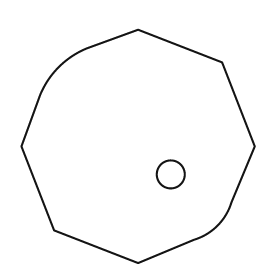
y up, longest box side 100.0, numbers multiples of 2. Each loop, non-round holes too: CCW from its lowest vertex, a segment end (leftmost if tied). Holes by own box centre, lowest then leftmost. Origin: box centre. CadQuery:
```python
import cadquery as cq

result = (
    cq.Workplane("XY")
    .moveTo(0.0, -50.0)
    .lineTo(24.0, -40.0)
    .threePointArc((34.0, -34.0), (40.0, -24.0))
    .lineTo(50.0, 0.0)
    .lineTo(36.0, 36.0)
    .lineTo(0.0, 50.0)
    .lineTo(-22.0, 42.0)
    .threePointArc((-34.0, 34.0), (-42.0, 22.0))
    .lineTo(-50.0, 0.0)
    .lineTo(-36.0, -36.0)
    .close()
    .moveTo(14.0, -12.0)
    .circle(6.0)
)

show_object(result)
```